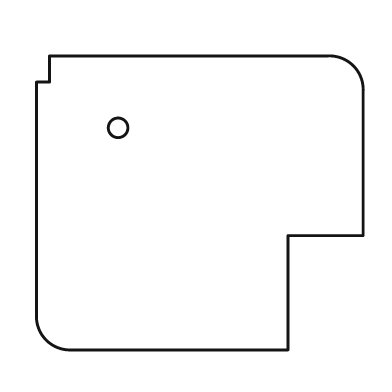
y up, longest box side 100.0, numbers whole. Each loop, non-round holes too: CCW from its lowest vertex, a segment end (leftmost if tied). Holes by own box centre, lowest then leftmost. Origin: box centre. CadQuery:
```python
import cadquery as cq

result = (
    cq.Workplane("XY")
    .moveTo(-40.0, -45.0)
    .lineTo(27.0, -45.0)
    .lineTo(27.0, -10.0)
    .lineTo(50.0, -10.0)
    .lineTo(50.0, 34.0)
    .threePointArc((47.0, 42.0), (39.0, 45.0))
    .lineTo(-46.0, 45.0)
    .lineTo(-46.0, 37.0)
    .lineTo(-50.0, 37.0)
    .lineTo(-50.0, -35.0)
    .threePointArc((-47.0, -42.0), (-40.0, -45.0))
    .close()
    .moveTo(-25.0, 23.0)
    .circle(3.0)
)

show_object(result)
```